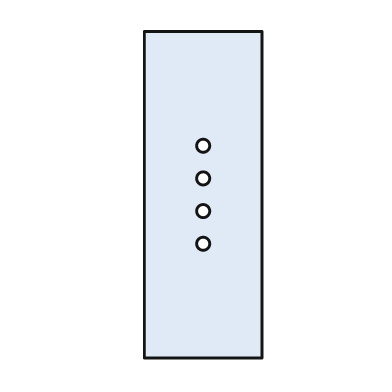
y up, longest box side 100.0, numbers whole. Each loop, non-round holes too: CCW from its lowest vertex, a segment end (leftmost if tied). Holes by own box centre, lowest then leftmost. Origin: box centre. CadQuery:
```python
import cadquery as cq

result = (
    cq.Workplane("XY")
    .moveTo(-18.0, -50.0)
    .lineTo(18.0, -50.0)
    .lineTo(18.0, 50.0)
    .lineTo(-18.0, 50.0)
    .close()
    .moveTo(0.0, -15.0)
    .circle(2.0)
    .moveTo(0.0, -5.0)
    .circle(2.0)
    .moveTo(0.0, 5.0)
    .circle(2.0)
    .moveTo(0.0, 15.0)
    .circle(2.0)
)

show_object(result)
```